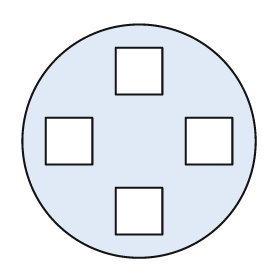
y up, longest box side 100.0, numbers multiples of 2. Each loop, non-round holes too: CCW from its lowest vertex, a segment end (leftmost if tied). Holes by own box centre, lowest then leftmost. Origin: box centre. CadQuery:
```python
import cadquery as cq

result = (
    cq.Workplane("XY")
    .moveTo(0.0, 0.0)
    .circle(50.0)
    .moveTo(-10.0, -40.0)
    .lineTo(10.0, -40.0)
    .lineTo(10.0, -20.0)
    .lineTo(-10.0, -20.0)
    .close()
    .moveTo(-40.0, -10.0)
    .lineTo(-20.0, -10.0)
    .lineTo(-20.0, 10.0)
    .lineTo(-40.0, 10.0)
    .close()
    .moveTo(20.0, -10.0)
    .lineTo(40.0, -10.0)
    .lineTo(40.0, 10.0)
    .lineTo(20.0, 10.0)
    .close()
    .moveTo(-10.0, 20.0)
    .lineTo(10.0, 20.0)
    .lineTo(10.0, 40.0)
    .lineTo(-10.0, 40.0)
    .close()
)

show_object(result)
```